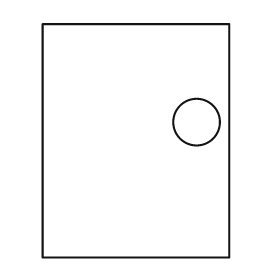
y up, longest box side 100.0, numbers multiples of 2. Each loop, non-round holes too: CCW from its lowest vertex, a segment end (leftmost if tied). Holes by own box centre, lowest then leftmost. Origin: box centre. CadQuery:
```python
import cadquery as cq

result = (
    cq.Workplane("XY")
    .moveTo(-40.0, -50.0)
    .lineTo(40.0, -50.0)
    .lineTo(40.0, 50.0)
    .lineTo(-40.0, 50.0)
    .close()
    .moveTo(26.0, 8.0)
    .circle(10.0)
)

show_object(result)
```